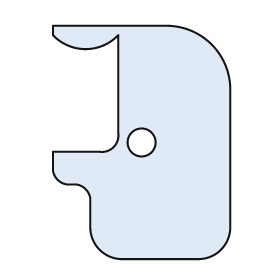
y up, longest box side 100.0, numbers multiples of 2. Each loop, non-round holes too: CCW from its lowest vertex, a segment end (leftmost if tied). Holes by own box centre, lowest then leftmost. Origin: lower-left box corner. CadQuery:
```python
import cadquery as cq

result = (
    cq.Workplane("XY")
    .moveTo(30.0, 0.0)
    .lineTo(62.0, 0.0)
    .threePointArc((72.0, 4.0), (76.0, 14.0))
    .lineTo(76.0, 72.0)
    .threePointArc((68.0, 92.0), (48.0, 100.0))
    .lineTo(0.0, 100.0)
    .lineTo(0.0, 96.0)
    .threePointArc((14.0, 90.0), (28.0, 96.0))
    .lineTo(28.0, 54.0)
    .threePointArc((26.0, 48.0), (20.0, 46.0))
    .lineTo(0.0, 46.0)
    .lineTo(0.0, 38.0)
    .threePointArc((2.0, 34.0), (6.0, 32.0))
    .lineTo(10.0, 32.0)
    .threePointArc((14.0, 30.0), (16.0, 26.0))
    .lineTo(16.0, 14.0)
    .threePointArc((20.0, 4.0), (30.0, 0.0))
    .close()
    .moveTo(38.0, 50.0)
    .circle(6.0)
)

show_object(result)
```